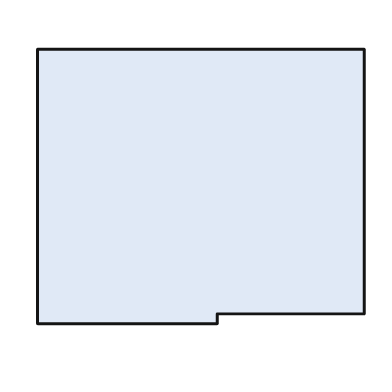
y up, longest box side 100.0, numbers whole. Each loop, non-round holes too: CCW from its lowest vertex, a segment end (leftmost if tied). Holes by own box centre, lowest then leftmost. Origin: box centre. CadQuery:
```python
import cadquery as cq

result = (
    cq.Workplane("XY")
    .moveTo(-50.0, -42.0)
    .lineTo(5.0, -42.0)
    .lineTo(5.0, -39.0)
    .lineTo(50.0, -39.0)
    .lineTo(50.0, 42.0)
    .lineTo(-50.0, 42.0)
    .close()
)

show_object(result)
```